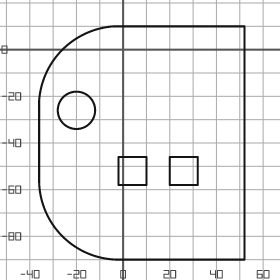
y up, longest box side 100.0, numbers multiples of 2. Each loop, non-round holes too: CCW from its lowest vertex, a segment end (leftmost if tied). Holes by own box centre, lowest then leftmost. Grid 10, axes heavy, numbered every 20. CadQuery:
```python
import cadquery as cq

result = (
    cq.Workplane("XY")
    .moveTo(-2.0, -90.0)
    .lineTo(52.0, -90.0)
    .lineTo(52.0, 10.0)
    .lineTo(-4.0, 10.0)
    .threePointArc((-26.0, 0.0), (-36.0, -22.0))
    .lineTo(-36.0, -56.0)
    .threePointArc((-26.0, -80.0), (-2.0, -90.0))
    .close()
    .moveTo(-2.0, -58.0)
    .lineTo(10.0, -58.0)
    .lineTo(10.0, -46.0)
    .lineTo(-2.0, -46.0)
    .close()
    .moveTo(20.0, -58.0)
    .lineTo(32.0, -58.0)
    .lineTo(32.0, -46.0)
    .lineTo(20.0, -46.0)
    .close()
    .moveTo(-20.0, -26.0)
    .circle(8.0)
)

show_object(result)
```